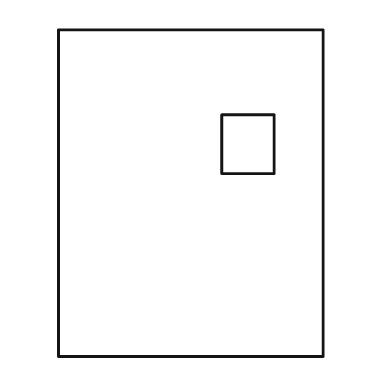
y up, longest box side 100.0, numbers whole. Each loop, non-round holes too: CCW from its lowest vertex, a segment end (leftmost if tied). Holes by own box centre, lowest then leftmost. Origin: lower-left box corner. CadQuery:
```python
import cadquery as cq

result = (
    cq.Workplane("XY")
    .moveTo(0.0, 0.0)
    .lineTo(81.0, 0.0)
    .lineTo(81.0, 100.0)
    .lineTo(0.0, 100.0)
    .close()
    .moveTo(50.0, 56.0)
    .lineTo(66.0, 56.0)
    .lineTo(66.0, 74.0)
    .lineTo(50.0, 74.0)
    .close()
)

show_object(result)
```